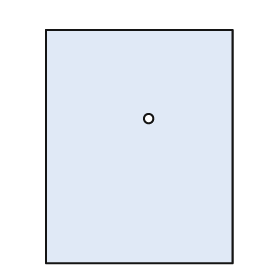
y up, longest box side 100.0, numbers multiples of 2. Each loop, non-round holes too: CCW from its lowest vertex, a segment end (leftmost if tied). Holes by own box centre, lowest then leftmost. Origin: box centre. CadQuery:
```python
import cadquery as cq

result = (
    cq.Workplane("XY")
    .moveTo(-40.0, -50.0)
    .lineTo(40.0, -50.0)
    .lineTo(40.0, 50.0)
    .lineTo(-40.0, 50.0)
    .close()
    .moveTo(4.0, 12.0)
    .circle(2.0)
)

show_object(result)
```